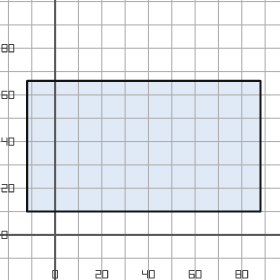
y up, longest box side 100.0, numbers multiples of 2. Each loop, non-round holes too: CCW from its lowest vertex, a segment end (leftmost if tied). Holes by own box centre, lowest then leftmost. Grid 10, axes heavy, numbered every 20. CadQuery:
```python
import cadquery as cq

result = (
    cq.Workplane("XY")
    .moveTo(-12.0, 10.0)
    .lineTo(88.0, 10.0)
    .lineTo(88.0, 66.0)
    .lineTo(-12.0, 66.0)
    .close()
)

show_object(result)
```